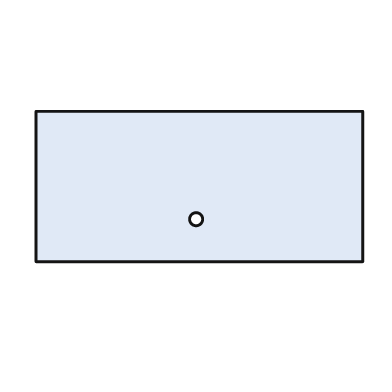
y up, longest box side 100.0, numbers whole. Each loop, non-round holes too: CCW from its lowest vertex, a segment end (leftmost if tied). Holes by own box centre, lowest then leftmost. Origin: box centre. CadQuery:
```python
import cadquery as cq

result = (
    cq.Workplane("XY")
    .moveTo(-50.0, -23.0)
    .lineTo(50.0, -23.0)
    .lineTo(50.0, 23.0)
    .lineTo(-50.0, 23.0)
    .close()
    .moveTo(-1.0, -10.0)
    .circle(2.0)
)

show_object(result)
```